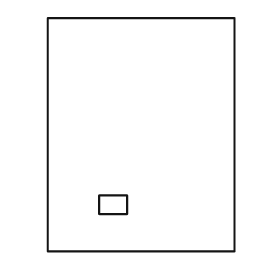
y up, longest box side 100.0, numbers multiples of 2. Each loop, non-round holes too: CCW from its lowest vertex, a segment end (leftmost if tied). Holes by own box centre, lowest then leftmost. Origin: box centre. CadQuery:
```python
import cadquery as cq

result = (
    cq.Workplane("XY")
    .moveTo(-40.0, -50.0)
    .lineTo(40.0, -50.0)
    .lineTo(40.0, 50.0)
    .lineTo(-40.0, 50.0)
    .close()
    .moveTo(-18.0, -34.0)
    .lineTo(-6.0, -34.0)
    .lineTo(-6.0, -26.0)
    .lineTo(-18.0, -26.0)
    .close()
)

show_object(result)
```